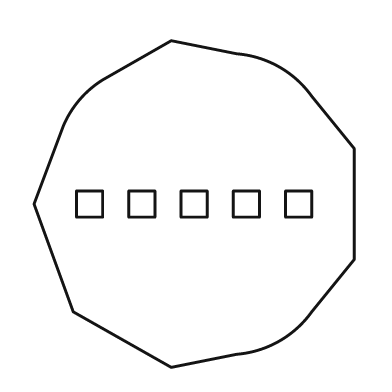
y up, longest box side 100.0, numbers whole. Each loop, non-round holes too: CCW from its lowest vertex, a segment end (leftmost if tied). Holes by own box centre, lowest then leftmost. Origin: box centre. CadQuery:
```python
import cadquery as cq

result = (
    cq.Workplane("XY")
    .moveTo(-7.0, -50.0)
    .lineTo(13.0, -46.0)
    .threePointArc((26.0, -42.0), (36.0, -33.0))
    .lineTo(49.0, -17.0)
    .lineTo(49.0, 17.0)
    .lineTo(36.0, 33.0)
    .threePointArc((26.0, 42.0), (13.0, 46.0))
    .lineTo(-7.0, 50.0)
    .lineTo(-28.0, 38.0)
    .threePointArc((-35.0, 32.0), (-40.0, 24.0))
    .lineTo(-49.0, 0.0)
    .lineTo(-37.0, -33.0)
    .close()
    .moveTo(-36.0, -4.0)
    .lineTo(-28.0, -4.0)
    .lineTo(-28.0, 4.0)
    .lineTo(-36.0, 4.0)
    .close()
    .moveTo(-20.0, -4.0)
    .lineTo(-12.0, -4.0)
    .lineTo(-12.0, 4.0)
    .lineTo(-20.0, 4.0)
    .close()
    .moveTo(-4.0, -4.0)
    .lineTo(4.0, -4.0)
    .lineTo(4.0, 4.0)
    .lineTo(-4.0, 4.0)
    .close()
    .moveTo(12.0, -4.0)
    .lineTo(20.0, -4.0)
    .lineTo(20.0, 4.0)
    .lineTo(12.0, 4.0)
    .close()
    .moveTo(28.0, -4.0)
    .lineTo(36.0, -4.0)
    .lineTo(36.0, 4.0)
    .lineTo(28.0, 4.0)
    .close()
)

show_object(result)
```